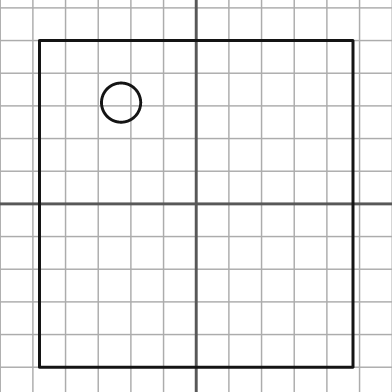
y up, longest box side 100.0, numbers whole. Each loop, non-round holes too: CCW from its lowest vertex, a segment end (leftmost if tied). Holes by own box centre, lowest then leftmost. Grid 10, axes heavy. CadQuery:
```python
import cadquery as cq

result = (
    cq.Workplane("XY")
    .moveTo(-48.0, -50.0)
    .lineTo(48.0, -50.0)
    .lineTo(48.0, 50.0)
    .lineTo(-48.0, 50.0)
    .close()
    .moveTo(-23.0, 31.0)
    .circle(6.0)
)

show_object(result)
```